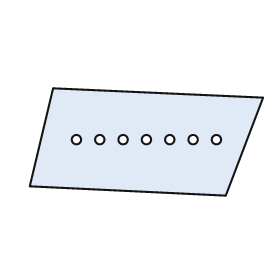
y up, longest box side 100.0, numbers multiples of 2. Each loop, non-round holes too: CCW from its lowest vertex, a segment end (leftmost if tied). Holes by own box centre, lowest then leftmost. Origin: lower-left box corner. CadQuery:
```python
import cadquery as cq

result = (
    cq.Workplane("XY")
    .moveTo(84.0, 0.0)
    .lineTo(100.0, 42.0)
    .lineTo(10.0, 46.0)
    .lineTo(0.0, 4.0)
    .close()
    .moveTo(20.0, 24.0)
    .circle(2.0)
    .moveTo(30.0, 24.0)
    .circle(2.0)
    .moveTo(40.0, 24.0)
    .circle(2.0)
    .moveTo(50.0, 24.0)
    .circle(2.0)
    .moveTo(60.0, 24.0)
    .circle(2.0)
    .moveTo(70.0, 24.0)
    .circle(2.0)
    .moveTo(80.0, 24.0)
    .circle(2.0)
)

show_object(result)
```